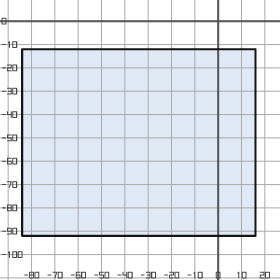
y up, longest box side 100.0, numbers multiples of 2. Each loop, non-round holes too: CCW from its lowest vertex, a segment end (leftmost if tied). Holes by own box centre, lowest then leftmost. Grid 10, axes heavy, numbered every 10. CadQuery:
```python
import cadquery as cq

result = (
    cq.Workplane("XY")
    .moveTo(-84.0, -92.0)
    .lineTo(16.0, -92.0)
    .lineTo(16.0, -12.0)
    .lineTo(-84.0, -12.0)
    .close()
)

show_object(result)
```